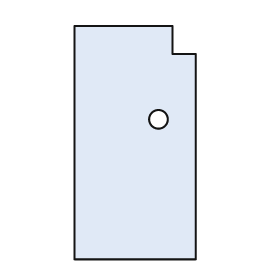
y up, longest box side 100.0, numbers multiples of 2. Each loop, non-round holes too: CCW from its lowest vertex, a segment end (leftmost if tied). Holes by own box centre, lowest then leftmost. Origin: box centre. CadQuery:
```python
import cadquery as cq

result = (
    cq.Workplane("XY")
    .moveTo(-26.0, -50.0)
    .lineTo(26.0, -50.0)
    .lineTo(26.0, 38.0)
    .lineTo(16.0, 38.0)
    .lineTo(16.0, 50.0)
    .lineTo(-26.0, 50.0)
    .close()
    .moveTo(10.0, 10.0)
    .circle(4.0)
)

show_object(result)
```